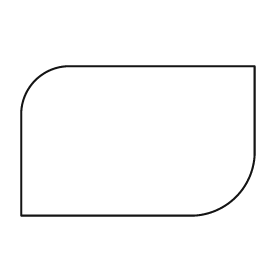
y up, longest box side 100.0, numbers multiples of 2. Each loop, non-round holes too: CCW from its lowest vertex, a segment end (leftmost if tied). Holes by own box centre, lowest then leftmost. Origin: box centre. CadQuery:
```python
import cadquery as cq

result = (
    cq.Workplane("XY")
    .moveTo(-50.0, -32.0)
    .lineTo(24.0, -32.0)
    .threePointArc((42.0, -24.0), (50.0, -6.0))
    .lineTo(50.0, 32.0)
    .lineTo(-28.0, 32.0)
    .threePointArc((-44.0, 26.0), (-50.0, 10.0))
    .close()
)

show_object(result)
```